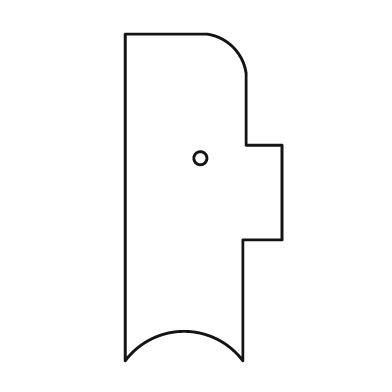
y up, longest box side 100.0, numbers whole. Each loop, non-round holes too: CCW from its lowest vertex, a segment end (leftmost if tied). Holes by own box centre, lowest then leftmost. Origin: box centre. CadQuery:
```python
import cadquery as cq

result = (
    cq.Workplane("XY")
    .moveTo(-24.0, -50.0)
    .threePointArc((-6.0, -41.0), (12.0, -50.0))
    .lineTo(12.0, -13.0)
    .lineTo(24.0, -13.0)
    .lineTo(24.0, 16.0)
    .lineTo(13.0, 16.0)
    .lineTo(13.0, 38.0)
    .threePointArc((9.0, 46.0), (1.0, 50.0))
    .lineTo(-24.0, 50.0)
    .close()
    .moveTo(-1.0, 12.0)
    .circle(2.0)
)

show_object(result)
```